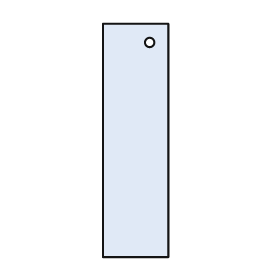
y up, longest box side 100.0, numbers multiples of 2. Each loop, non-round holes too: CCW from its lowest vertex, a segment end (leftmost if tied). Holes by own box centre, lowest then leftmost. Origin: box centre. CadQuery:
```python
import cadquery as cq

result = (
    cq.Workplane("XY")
    .moveTo(-14.0, -50.0)
    .lineTo(14.0, -50.0)
    .lineTo(14.0, 50.0)
    .lineTo(-14.0, 50.0)
    .close()
    .moveTo(6.0, 42.0)
    .circle(2.0)
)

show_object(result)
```